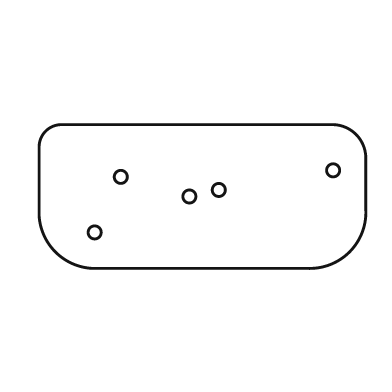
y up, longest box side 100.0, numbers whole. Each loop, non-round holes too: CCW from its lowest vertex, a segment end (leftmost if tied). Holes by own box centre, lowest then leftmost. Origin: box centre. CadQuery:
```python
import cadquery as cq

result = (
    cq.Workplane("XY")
    .moveTo(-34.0, -22.0)
    .lineTo(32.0, -22.0)
    .threePointArc((45.0, -17.0), (50.0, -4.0))
    .lineTo(50.0, 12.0)
    .threePointArc((47.0, 19.0), (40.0, 22.0))
    .lineTo(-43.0, 22.0)
    .threePointArc((-48.0, 20.0), (-50.0, 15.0))
    .lineTo(-50.0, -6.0)
    .threePointArc((-45.0, -17.0), (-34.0, -22.0))
    .close()
    .moveTo(-33.0, -11.0)
    .circle(2.0)
    .moveTo(-4.0, 0.0)
    .circle(2.0)
    .moveTo(5.0, 2.0)
    .circle(2.0)
    .moveTo(-25.0, 6.0)
    .circle(2.0)
    .moveTo(40.0, 8.0)
    .circle(2.0)
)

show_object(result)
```